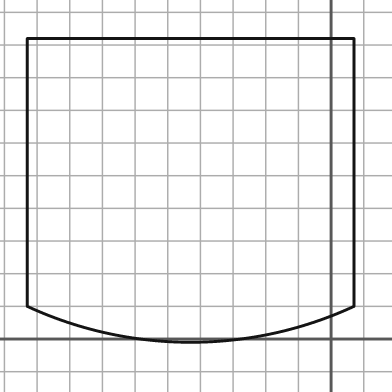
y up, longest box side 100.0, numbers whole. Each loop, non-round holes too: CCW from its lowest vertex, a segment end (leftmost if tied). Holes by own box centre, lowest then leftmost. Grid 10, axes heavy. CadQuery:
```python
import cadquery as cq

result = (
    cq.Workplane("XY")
    .moveTo(-93.0, 10.0)
    .threePointArc((-43.0, -1.0), (7.0, 10.0))
    .lineTo(7.0, 92.0)
    .lineTo(-93.0, 92.0)
    .close()
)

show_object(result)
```